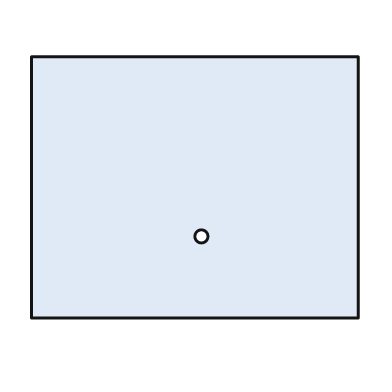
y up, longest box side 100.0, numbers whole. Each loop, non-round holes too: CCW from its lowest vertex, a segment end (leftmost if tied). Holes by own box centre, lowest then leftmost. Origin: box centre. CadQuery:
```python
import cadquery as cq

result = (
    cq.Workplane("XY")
    .moveTo(-50.0, -40.0)
    .lineTo(50.0, -40.0)
    .lineTo(50.0, 40.0)
    .lineTo(-50.0, 40.0)
    .close()
    .moveTo(2.0, -15.0)
    .circle(2.0)
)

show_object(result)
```